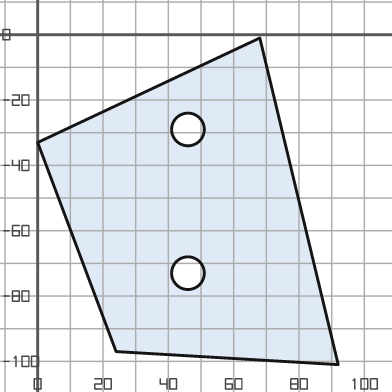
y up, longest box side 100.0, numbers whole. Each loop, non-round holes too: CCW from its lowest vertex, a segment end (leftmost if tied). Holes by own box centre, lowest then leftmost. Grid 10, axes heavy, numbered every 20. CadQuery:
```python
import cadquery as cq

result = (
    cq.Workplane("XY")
    .moveTo(92.0, -101.0)
    .lineTo(68.0, -1.0)
    .lineTo(0.0, -33.0)
    .lineTo(24.0, -97.0)
    .close()
    .moveTo(46.0, -73.0)
    .circle(5.0)
    .moveTo(46.0, -29.0)
    .circle(5.0)
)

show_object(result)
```